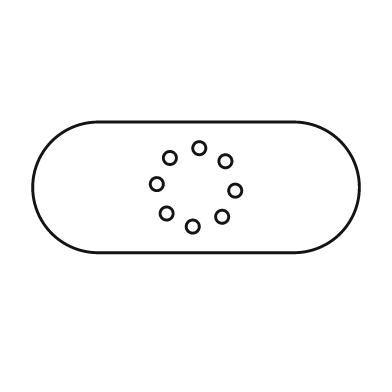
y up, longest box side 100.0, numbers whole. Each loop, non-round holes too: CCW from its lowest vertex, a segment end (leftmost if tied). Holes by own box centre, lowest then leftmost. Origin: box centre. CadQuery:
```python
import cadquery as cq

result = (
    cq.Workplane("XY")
    .moveTo(-30.0, -20.0)
    .lineTo(30.0, -20.0)
    .threePointArc((50.0, 0.0), (30.0, 20.0))
    .lineTo(-30.0, 20.0)
    .threePointArc((-50.0, 0.0), (-30.0, -20.0))
    .close()
    .moveTo(-1.0, -12.0)
    .circle(2.0)
    .moveTo(8.0, -9.0)
    .circle(2.0)
    .moveTo(-9.0, -8.0)
    .circle(2.0)
    .moveTo(12.0, -1.0)
    .circle(2.0)
    .moveTo(-12.0, 1.0)
    .circle(2.0)
    .moveTo(9.0, 8.0)
    .circle(2.0)
    .moveTo(-8.0, 9.0)
    .circle(2.0)
    .moveTo(1.0, 12.0)
    .circle(2.0)
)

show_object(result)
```